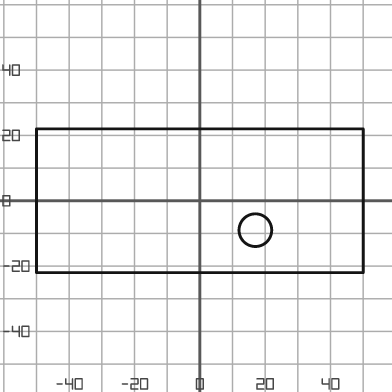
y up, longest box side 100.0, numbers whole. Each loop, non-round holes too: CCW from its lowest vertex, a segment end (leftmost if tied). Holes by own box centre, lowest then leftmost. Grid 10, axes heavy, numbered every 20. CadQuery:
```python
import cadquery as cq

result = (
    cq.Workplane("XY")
    .moveTo(-50.0, -22.0)
    .lineTo(50.0, -22.0)
    .lineTo(50.0, 22.0)
    .lineTo(-50.0, 22.0)
    .close()
    .moveTo(17.0, -9.0)
    .circle(5.0)
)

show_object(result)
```